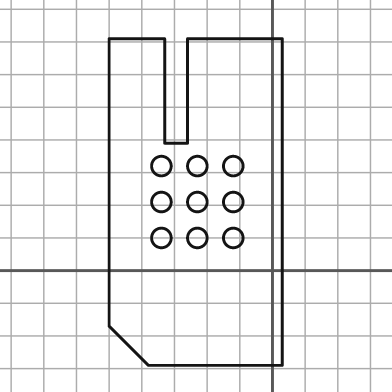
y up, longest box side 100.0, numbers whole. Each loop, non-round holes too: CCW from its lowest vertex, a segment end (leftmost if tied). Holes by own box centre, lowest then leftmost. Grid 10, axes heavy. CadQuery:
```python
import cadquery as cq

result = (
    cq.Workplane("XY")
    .moveTo(-38.0, -29.0)
    .lineTo(3.0, -29.0)
    .lineTo(3.0, 71.0)
    .lineTo(-26.0, 71.0)
    .lineTo(-26.0, 39.0)
    .lineTo(-33.0, 39.0)
    .lineTo(-33.0, 71.0)
    .lineTo(-50.0, 71.0)
    .lineTo(-50.0, -17.0)
    .close()
    .moveTo(-34.0, 10.0)
    .circle(3.0)
    .moveTo(-23.0, 10.0)
    .circle(3.0)
    .moveTo(-12.0, 10.0)
    .circle(3.0)
    .moveTo(-34.0, 21.0)
    .circle(3.0)
    .moveTo(-23.0, 21.0)
    .circle(3.0)
    .moveTo(-12.0, 21.0)
    .circle(3.0)
    .moveTo(-34.0, 32.0)
    .circle(3.0)
    .moveTo(-23.0, 32.0)
    .circle(3.0)
    .moveTo(-12.0, 32.0)
    .circle(3.0)
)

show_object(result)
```